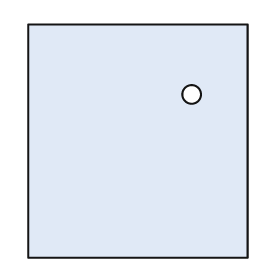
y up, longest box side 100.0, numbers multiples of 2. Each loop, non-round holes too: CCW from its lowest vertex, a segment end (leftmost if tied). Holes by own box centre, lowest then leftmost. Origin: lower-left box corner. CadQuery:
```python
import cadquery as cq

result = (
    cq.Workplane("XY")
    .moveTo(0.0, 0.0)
    .lineTo(94.0, 0.0)
    .lineTo(94.0, 100.0)
    .lineTo(0.0, 100.0)
    .close()
    .moveTo(70.0, 70.0)
    .circle(4.0)
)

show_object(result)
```